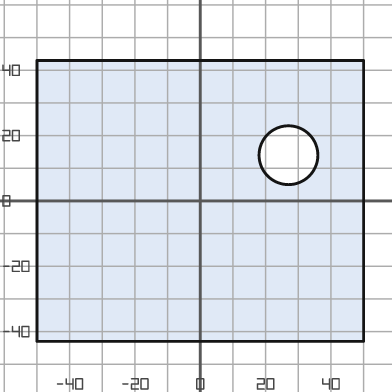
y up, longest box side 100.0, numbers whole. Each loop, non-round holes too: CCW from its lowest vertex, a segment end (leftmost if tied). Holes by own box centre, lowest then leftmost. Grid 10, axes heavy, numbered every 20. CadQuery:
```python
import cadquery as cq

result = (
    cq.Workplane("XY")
    .moveTo(-50.0, -43.0)
    .lineTo(50.0, -43.0)
    .lineTo(50.0, 43.0)
    .lineTo(-50.0, 43.0)
    .close()
    .moveTo(27.0, 14.0)
    .circle(9.0)
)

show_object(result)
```